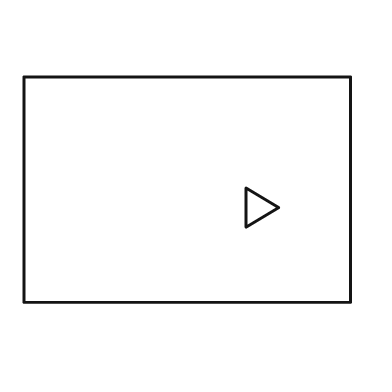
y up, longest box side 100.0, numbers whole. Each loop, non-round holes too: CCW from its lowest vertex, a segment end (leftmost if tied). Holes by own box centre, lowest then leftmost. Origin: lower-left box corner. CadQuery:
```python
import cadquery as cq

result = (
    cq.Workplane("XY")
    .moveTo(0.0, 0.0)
    .lineTo(100.0, 0.0)
    .lineTo(100.0, 69.0)
    .lineTo(0.0, 69.0)
    .close()
    .moveTo(68.0, 23.0)
    .lineTo(78.0, 29.0)
    .lineTo(68.0, 35.0)
    .close()
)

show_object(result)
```